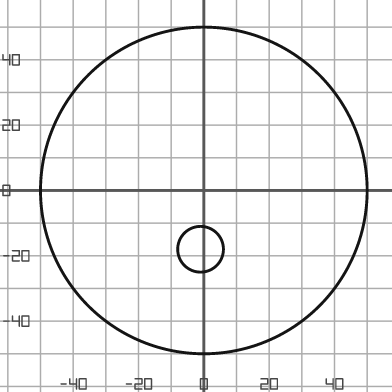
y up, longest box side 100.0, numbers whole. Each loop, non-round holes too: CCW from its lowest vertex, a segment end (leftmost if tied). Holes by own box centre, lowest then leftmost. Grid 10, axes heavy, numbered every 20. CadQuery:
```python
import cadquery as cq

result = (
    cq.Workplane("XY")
    .moveTo(0.0, 0.0)
    .circle(50.0)
    .moveTo(-1.0, -18.0)
    .circle(7.0)
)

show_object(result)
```